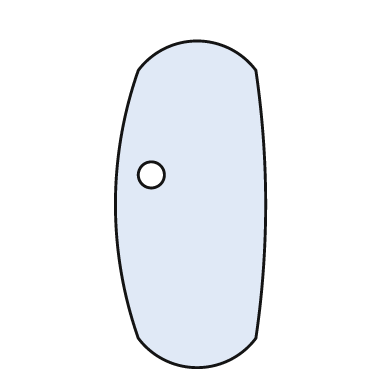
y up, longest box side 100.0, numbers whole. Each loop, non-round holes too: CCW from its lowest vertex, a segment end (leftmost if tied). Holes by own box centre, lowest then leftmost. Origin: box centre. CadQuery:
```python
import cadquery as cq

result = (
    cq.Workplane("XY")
    .moveTo(-16.0, -41.0)
    .threePointArc((2.0, -50.0), (20.0, -41.0))
    .threePointArc((23.0, 0.0), (20.0, 41.0))
    .threePointArc((2.0, 50.0), (-16.0, 41.0))
    .threePointArc((-23.0, 0.0), (-16.0, -41.0))
    .close()
    .moveTo(-12.0, 9.0)
    .circle(4.0)
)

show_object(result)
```